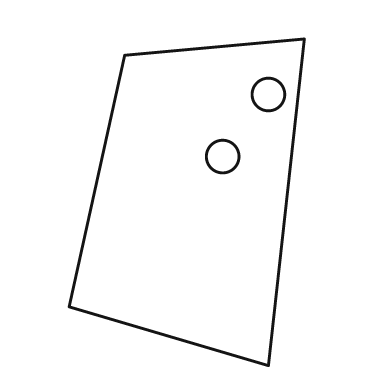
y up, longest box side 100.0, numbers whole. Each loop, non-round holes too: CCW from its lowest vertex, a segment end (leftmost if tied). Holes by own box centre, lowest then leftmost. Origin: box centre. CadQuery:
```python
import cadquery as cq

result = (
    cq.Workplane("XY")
    .moveTo(25.0, -50.0)
    .lineTo(36.0, 50.0)
    .lineTo(-19.0, 45.0)
    .lineTo(-36.0, -32.0)
    .close()
    .moveTo(11.0, 14.0)
    .circle(5.0)
    .moveTo(25.0, 33.0)
    .circle(5.0)
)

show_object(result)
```